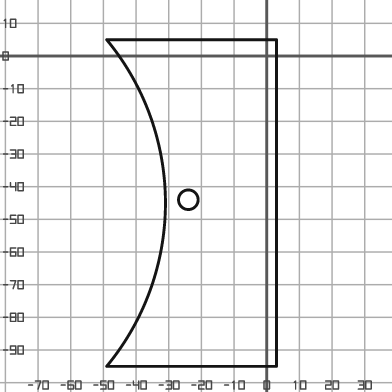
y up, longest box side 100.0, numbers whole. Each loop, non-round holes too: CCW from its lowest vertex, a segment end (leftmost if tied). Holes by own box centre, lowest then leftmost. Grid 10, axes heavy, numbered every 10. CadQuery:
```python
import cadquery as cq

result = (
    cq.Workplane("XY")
    .moveTo(-49.0, -95.0)
    .lineTo(3.0, -95.0)
    .lineTo(3.0, 5.0)
    .lineTo(-49.0, 5.0)
    .threePointArc((-31.0, -45.0), (-49.0, -95.0))
    .close()
    .moveTo(-24.0, -44.0)
    .circle(3.0)
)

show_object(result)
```